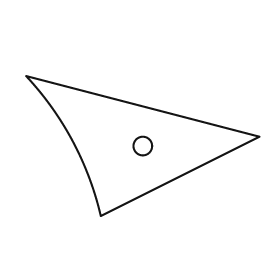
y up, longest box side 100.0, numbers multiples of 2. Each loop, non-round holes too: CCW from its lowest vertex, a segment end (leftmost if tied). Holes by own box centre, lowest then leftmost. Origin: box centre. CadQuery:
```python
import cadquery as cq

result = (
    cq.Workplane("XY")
    .moveTo(-18.0, -30.0)
    .lineTo(50.0, 4.0)
    .lineTo(-50.0, 30.0)
    .threePointArc((-30.0, 2.0), (-18.0, -30.0))
    .close()
    .moveTo(0.0, 0.0)
    .circle(4.0)
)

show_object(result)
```